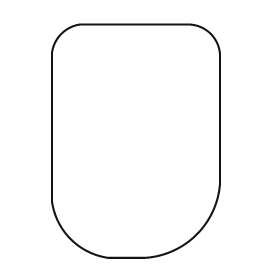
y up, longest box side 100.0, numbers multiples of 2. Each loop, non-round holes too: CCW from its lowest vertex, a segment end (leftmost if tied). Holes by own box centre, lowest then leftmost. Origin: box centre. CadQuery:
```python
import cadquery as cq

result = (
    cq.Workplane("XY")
    .moveTo(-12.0, -50.0)
    .lineTo(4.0, -50.0)
    .threePointArc((26.0, -40.0), (36.0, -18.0))
    .lineTo(36.0, 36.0)
    .threePointArc((32.0, 46.0), (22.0, 50.0))
    .lineTo(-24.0, 50.0)
    .threePointArc((-32.0, 46.0), (-36.0, 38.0))
    .lineTo(-36.0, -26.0)
    .threePointArc((-28.0, -42.0), (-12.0, -50.0))
    .close()
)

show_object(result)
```